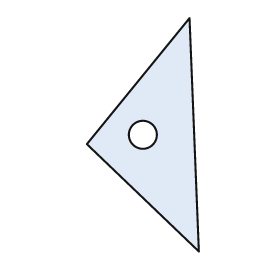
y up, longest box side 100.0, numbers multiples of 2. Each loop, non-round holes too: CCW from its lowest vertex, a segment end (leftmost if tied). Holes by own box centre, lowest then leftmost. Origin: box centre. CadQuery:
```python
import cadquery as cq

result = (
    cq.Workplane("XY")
    .moveTo(24.0, -50.0)
    .lineTo(20.0, 50.0)
    .lineTo(-24.0, -4.0)
    .close()
    .moveTo(0.0, 0.0)
    .circle(6.0)
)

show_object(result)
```